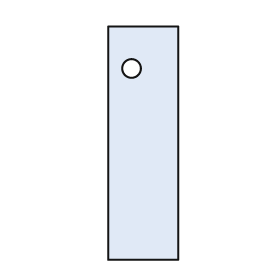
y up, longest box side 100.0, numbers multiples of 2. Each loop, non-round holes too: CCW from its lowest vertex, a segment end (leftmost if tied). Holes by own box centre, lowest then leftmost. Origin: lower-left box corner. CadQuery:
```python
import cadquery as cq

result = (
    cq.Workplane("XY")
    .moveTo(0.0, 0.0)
    .lineTo(30.0, 0.0)
    .lineTo(30.0, 100.0)
    .lineTo(0.0, 100.0)
    .close()
    .moveTo(10.0, 82.0)
    .circle(4.0)
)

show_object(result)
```